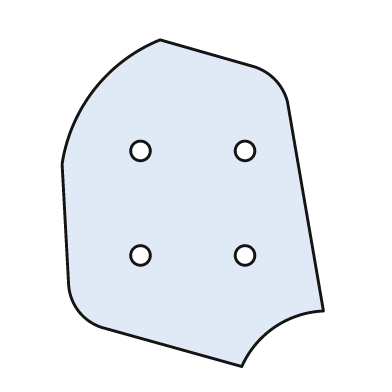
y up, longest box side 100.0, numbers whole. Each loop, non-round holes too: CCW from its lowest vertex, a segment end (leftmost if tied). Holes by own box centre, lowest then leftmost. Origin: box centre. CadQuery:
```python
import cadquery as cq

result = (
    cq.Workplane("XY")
    .moveTo(15.0, -50.0)
    .threePointArc((25.0, -38.0), (40.0, -33.0))
    .lineTo(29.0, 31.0)
    .threePointArc((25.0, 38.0), (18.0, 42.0))
    .lineTo(-10.0, 50.0)
    .threePointArc((-30.0, 35.0), (-40.0, 12.0))
    .lineTo(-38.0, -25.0)
    .threePointArc((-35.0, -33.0), (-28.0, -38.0))
    .close()
    .moveTo(-16.0, -16.0)
    .circle(3.0)
    .moveTo(16.0, -16.0)
    .circle(3.0)
    .moveTo(-16.0, 16.0)
    .circle(3.0)
    .moveTo(16.0, 16.0)
    .circle(3.0)
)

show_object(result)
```